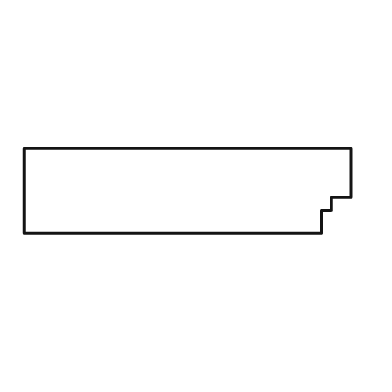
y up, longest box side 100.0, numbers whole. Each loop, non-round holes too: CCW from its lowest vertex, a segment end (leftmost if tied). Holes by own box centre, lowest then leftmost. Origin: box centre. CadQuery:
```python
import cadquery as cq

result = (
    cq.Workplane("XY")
    .moveTo(-50.0, -13.0)
    .lineTo(41.0, -13.0)
    .lineTo(41.0, -6.0)
    .lineTo(44.0, -6.0)
    .lineTo(44.0, -2.0)
    .lineTo(50.0, -2.0)
    .lineTo(50.0, 13.0)
    .lineTo(-50.0, 13.0)
    .close()
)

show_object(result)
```